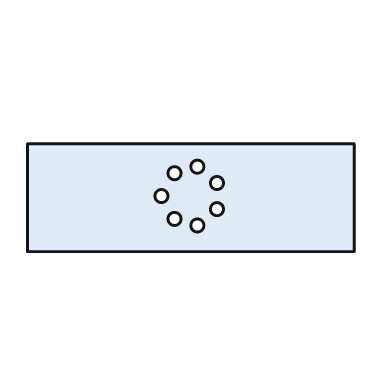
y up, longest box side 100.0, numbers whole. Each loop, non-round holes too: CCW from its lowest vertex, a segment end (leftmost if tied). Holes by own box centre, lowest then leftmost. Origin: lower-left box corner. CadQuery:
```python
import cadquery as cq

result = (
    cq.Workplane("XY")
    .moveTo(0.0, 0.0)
    .lineTo(100.0, 0.0)
    .lineTo(100.0, 33.0)
    .lineTo(0.0, 33.0)
    .close()
    .moveTo(52.0, 8.0)
    .circle(2.0)
    .moveTo(45.0, 10.0)
    .circle(2.0)
    .moveTo(58.0, 13.0)
    .circle(2.0)
    .moveTo(41.0, 17.0)
    .circle(2.0)
    .moveTo(58.0, 21.0)
    .circle(2.0)
    .moveTo(45.0, 24.0)
    .circle(2.0)
    .moveTo(52.0, 26.0)
    .circle(2.0)
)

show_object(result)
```